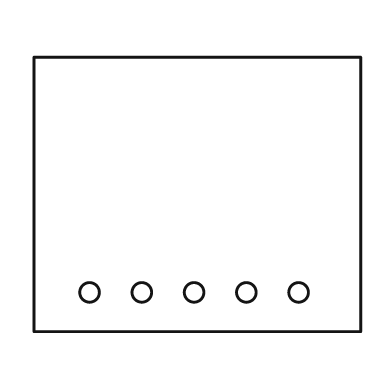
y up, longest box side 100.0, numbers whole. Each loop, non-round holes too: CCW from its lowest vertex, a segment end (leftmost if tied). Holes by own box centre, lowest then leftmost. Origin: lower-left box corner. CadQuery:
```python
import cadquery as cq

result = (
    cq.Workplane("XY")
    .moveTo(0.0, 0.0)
    .lineTo(100.0, 0.0)
    .lineTo(100.0, 84.0)
    .lineTo(0.0, 84.0)
    .close()
    .moveTo(17.0, 12.0)
    .circle(3.0)
    .moveTo(33.0, 12.0)
    .circle(3.0)
    .moveTo(49.0, 12.0)
    .circle(3.0)
    .moveTo(65.0, 12.0)
    .circle(3.0)
    .moveTo(81.0, 12.0)
    .circle(3.0)
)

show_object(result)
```